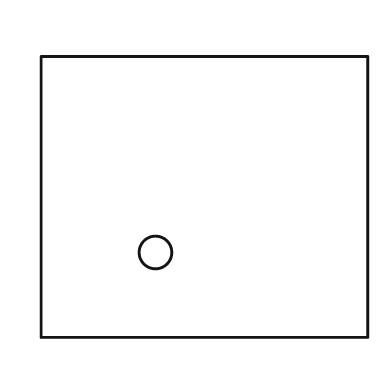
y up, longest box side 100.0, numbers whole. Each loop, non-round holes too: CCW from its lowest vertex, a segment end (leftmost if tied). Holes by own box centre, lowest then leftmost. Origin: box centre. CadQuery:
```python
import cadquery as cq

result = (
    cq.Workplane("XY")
    .moveTo(-50.0, -43.0)
    .lineTo(50.0, -43.0)
    .lineTo(50.0, 43.0)
    .lineTo(-50.0, 43.0)
    .close()
    .moveTo(-15.0, -17.0)
    .circle(5.0)
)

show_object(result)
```